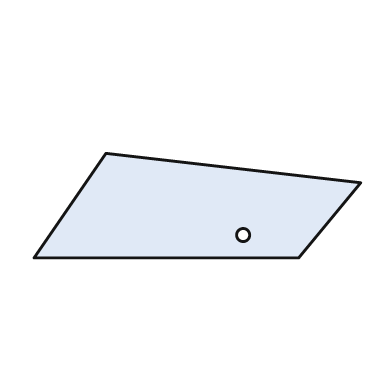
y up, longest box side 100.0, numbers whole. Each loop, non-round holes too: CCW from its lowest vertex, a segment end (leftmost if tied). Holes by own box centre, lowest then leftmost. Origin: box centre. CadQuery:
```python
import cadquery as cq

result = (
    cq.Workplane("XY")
    .moveTo(-50.0, -16.0)
    .lineTo(31.0, -16.0)
    .lineTo(50.0, 7.0)
    .lineTo(-28.0, 16.0)
    .close()
    .moveTo(14.0, -9.0)
    .circle(2.0)
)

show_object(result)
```